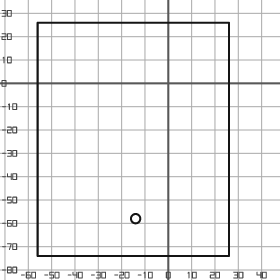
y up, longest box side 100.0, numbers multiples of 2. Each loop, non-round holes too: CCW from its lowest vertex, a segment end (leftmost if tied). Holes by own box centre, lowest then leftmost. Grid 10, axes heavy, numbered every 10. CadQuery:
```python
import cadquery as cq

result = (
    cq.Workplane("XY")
    .moveTo(-56.0, -74.0)
    .lineTo(26.0, -74.0)
    .lineTo(26.0, 26.0)
    .lineTo(-56.0, 26.0)
    .close()
    .moveTo(-14.0, -58.0)
    .circle(2.0)
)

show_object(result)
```